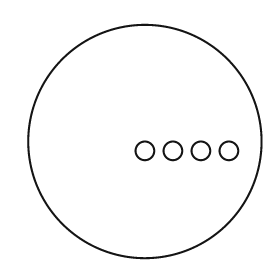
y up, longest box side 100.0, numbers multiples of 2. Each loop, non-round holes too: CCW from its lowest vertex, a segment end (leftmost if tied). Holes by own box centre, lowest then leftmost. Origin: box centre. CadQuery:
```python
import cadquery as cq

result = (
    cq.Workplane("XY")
    .moveTo(0.0, 0.0)
    .circle(50.0)
    .moveTo(0.0, -4.0)
    .circle(4.0)
    .moveTo(12.0, -4.0)
    .circle(4.0)
    .moveTo(24.0, -4.0)
    .circle(4.0)
    .moveTo(36.0, -4.0)
    .circle(4.0)
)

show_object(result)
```